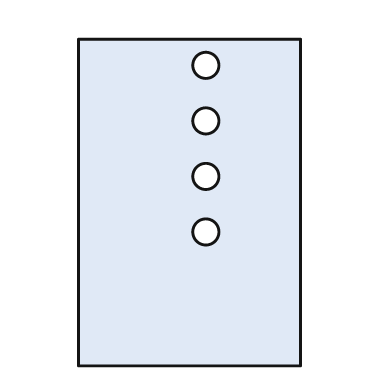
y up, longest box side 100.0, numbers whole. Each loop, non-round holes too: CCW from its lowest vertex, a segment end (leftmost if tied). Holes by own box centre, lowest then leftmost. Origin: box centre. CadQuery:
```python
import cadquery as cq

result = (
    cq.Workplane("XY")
    .moveTo(-34.0, -50.0)
    .lineTo(34.0, -50.0)
    .lineTo(34.0, 50.0)
    .lineTo(-34.0, 50.0)
    .close()
    .moveTo(5.0, -9.0)
    .circle(4.0)
    .moveTo(5.0, 8.0)
    .circle(4.0)
    .moveTo(5.0, 25.0)
    .circle(4.0)
    .moveTo(5.0, 42.0)
    .circle(4.0)
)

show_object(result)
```